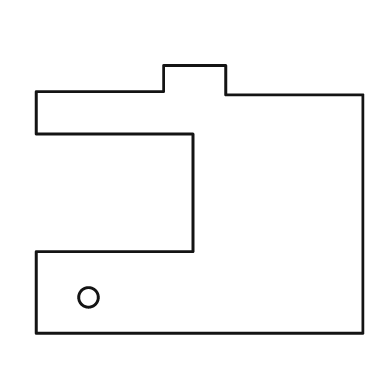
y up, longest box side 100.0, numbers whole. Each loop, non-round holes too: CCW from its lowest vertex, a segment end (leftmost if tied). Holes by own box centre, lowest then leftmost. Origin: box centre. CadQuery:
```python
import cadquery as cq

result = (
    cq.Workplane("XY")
    .moveTo(-50.0, -41.0)
    .lineTo(50.0, -41.0)
    .lineTo(50.0, 32.0)
    .lineTo(8.0, 32.0)
    .lineTo(8.0, 41.0)
    .lineTo(-11.0, 41.0)
    .lineTo(-11.0, 33.0)
    .lineTo(-50.0, 33.0)
    .lineTo(-50.0, 20.0)
    .lineTo(-2.0, 20.0)
    .lineTo(-2.0, -16.0)
    .lineTo(-50.0, -16.0)
    .close()
    .moveTo(-34.0, -30.0)
    .circle(3.0)
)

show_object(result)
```